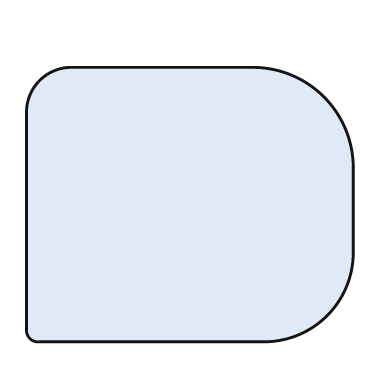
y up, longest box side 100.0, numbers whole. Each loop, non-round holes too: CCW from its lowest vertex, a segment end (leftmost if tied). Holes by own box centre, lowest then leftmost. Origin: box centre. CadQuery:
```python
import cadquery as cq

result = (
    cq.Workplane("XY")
    .moveTo(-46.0, -42.0)
    .lineTo(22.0, -42.0)
    .threePointArc((42.0, -34.0), (50.0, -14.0))
    .lineTo(50.0, 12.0)
    .threePointArc((41.0, 33.0), (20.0, 42.0))
    .lineTo(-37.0, 42.0)
    .threePointArc((-46.0, 38.0), (-50.0, 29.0))
    .lineTo(-50.0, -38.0)
    .threePointArc((-49.0, -41.0), (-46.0, -42.0))
    .close()
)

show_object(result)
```